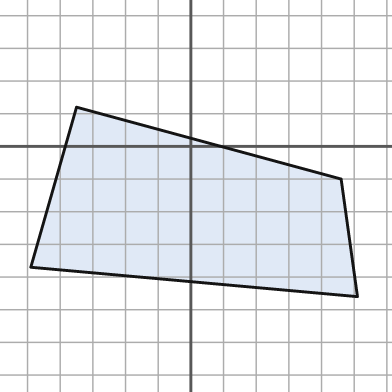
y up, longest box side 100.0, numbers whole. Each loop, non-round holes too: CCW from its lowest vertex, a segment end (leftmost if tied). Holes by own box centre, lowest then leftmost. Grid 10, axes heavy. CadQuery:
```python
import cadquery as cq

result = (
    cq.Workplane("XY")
    .moveTo(51.0, -46.0)
    .lineTo(46.0, -10.0)
    .lineTo(-35.0, 12.0)
    .lineTo(-49.0, -37.0)
    .close()
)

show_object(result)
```